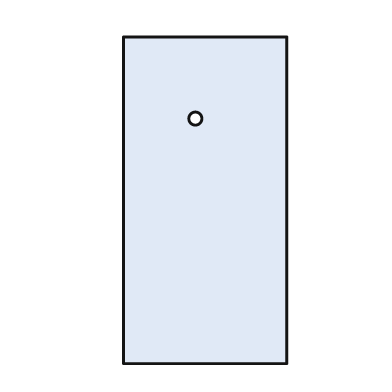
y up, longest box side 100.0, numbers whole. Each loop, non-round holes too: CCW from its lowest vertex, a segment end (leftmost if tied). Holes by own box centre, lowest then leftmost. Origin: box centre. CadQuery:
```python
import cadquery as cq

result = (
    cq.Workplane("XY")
    .moveTo(-25.0, -50.0)
    .lineTo(25.0, -50.0)
    .lineTo(25.0, 50.0)
    .lineTo(-25.0, 50.0)
    .close()
    .moveTo(-3.0, 25.0)
    .circle(2.0)
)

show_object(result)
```